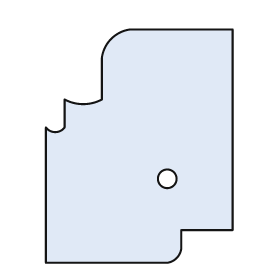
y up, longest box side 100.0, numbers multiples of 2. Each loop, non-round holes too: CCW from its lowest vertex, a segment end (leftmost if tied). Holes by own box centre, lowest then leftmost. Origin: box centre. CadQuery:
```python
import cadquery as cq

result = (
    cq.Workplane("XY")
    .moveTo(-40.0, -50.0)
    .lineTo(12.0, -50.0)
    .threePointArc((16.0, -48.0), (18.0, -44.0))
    .lineTo(18.0, -36.0)
    .lineTo(40.0, -36.0)
    .lineTo(40.0, 50.0)
    .lineTo(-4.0, 50.0)
    .threePointArc((-12.0, 46.0), (-16.0, 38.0))
    .lineTo(-16.0, 20.0)
    .threePointArc((-24.0, 18.0), (-32.0, 20.0))
    .lineTo(-32.0, 8.0)
    .threePointArc((-36.0, 6.0), (-40.0, 8.0))
    .close()
    .moveTo(12.0, -14.0)
    .circle(4.0)
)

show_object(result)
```